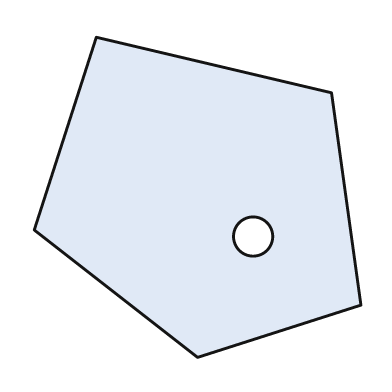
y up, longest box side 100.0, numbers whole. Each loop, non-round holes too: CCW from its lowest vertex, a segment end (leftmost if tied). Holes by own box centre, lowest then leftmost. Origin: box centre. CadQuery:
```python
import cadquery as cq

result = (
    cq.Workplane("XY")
    .moveTo(0.0, -49.0)
    .lineTo(50.0, -33.0)
    .lineTo(41.0, 32.0)
    .lineTo(-31.0, 49.0)
    .lineTo(-50.0, -10.0)
    .close()
    .moveTo(17.0, -12.0)
    .circle(6.0)
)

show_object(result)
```